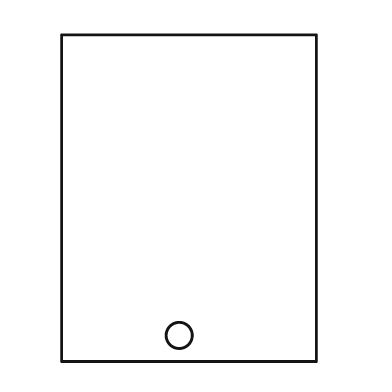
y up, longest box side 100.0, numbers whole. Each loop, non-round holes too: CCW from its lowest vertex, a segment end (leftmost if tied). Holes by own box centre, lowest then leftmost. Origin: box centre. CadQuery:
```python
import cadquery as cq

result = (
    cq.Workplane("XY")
    .moveTo(-39.0, -50.0)
    .lineTo(39.0, -50.0)
    .lineTo(39.0, 50.0)
    .lineTo(-39.0, 50.0)
    .close()
    .moveTo(-3.0, -42.0)
    .circle(4.0)
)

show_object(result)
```